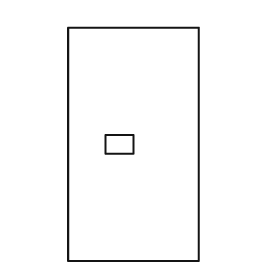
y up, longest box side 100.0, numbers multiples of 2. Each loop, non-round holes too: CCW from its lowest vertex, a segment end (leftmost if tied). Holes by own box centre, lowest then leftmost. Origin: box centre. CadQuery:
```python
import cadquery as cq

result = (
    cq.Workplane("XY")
    .moveTo(-28.0, -50.0)
    .lineTo(28.0, -50.0)
    .lineTo(28.0, 50.0)
    .lineTo(-28.0, 50.0)
    .close()
    .moveTo(-12.0, -4.0)
    .lineTo(0.0, -4.0)
    .lineTo(0.0, 4.0)
    .lineTo(-12.0, 4.0)
    .close()
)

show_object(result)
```